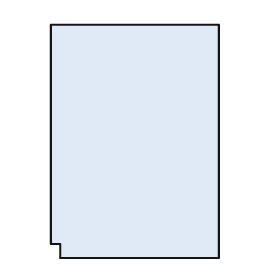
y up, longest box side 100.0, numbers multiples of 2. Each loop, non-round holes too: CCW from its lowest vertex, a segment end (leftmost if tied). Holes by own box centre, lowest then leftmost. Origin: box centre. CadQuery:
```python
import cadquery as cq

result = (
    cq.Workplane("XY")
    .moveTo(-32.0, -50.0)
    .lineTo(36.0, -50.0)
    .lineTo(36.0, 50.0)
    .lineTo(-36.0, 50.0)
    .lineTo(-36.0, -44.0)
    .lineTo(-32.0, -44.0)
    .close()
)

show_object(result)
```